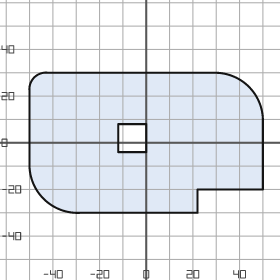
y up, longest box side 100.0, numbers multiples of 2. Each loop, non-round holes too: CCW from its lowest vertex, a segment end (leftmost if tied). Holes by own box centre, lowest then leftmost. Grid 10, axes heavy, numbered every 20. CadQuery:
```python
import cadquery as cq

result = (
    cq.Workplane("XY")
    .moveTo(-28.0, -30.0)
    .lineTo(22.0, -30.0)
    .lineTo(22.0, -20.0)
    .lineTo(50.0, -20.0)
    .lineTo(50.0, 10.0)
    .threePointArc((44.0, 24.0), (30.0, 30.0))
    .lineTo(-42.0, 30.0)
    .threePointArc((-48.0, 28.0), (-50.0, 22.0))
    .lineTo(-50.0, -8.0)
    .threePointArc((-44.0, -24.0), (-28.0, -30.0))
    .close()
    .moveTo(-12.0, -4.0)
    .lineTo(0.0, -4.0)
    .lineTo(0.0, 8.0)
    .lineTo(-12.0, 8.0)
    .close()
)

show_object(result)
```